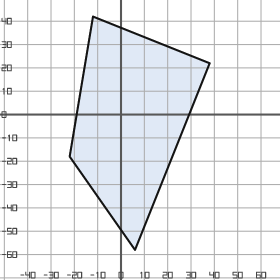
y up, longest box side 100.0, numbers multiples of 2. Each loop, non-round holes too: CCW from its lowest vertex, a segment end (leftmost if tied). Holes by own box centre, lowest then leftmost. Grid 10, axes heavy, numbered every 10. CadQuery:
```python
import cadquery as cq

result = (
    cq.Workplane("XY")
    .moveTo(6.0, -58.0)
    .lineTo(38.0, 22.0)
    .lineTo(-12.0, 42.0)
    .lineTo(-22.0, -18.0)
    .close()
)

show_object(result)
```